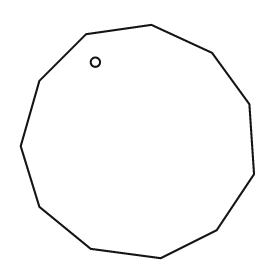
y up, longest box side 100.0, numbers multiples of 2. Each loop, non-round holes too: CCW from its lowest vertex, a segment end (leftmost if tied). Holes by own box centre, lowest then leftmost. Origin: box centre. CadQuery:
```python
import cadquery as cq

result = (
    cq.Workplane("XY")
    .moveTo(10.0, -50.0)
    .lineTo(34.0, -38.0)
    .lineTo(50.0, -14.0)
    .lineTo(48.0, 16.0)
    .lineTo(32.0, 38.0)
    .lineTo(6.0, 50.0)
    .lineTo(-22.0, 46.0)
    .lineTo(-42.0, 26.0)
    .lineTo(-50.0, -2.0)
    .lineTo(-42.0, -28.0)
    .lineTo(-20.0, -46.0)
    .close()
    .moveTo(-18.0, 34.0)
    .circle(2.0)
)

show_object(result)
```